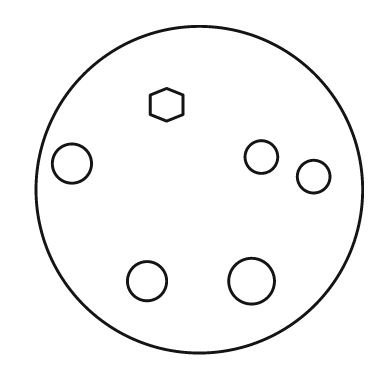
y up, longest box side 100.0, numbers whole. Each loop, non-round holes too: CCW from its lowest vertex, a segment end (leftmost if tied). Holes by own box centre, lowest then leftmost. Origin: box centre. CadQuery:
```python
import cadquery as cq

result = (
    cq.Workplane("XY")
    .moveTo(0.0, 0.0)
    .circle(50.0)
    .moveTo(-16.0, -28.0)
    .circle(6.0)
    .moveTo(16.0, -28.0)
    .circle(7.0)
    .moveTo(35.0, 4.0)
    .circle(5.0)
    .moveTo(-39.0, 8.0)
    .circle(6.0)
    .moveTo(19.0, 10.0)
    .circle(5.0)
    .moveTo(-10.0, 21.0)
    .lineTo(-5.0, 23.0)
    .lineTo(-5.0, 29.0)
    .lineTo(-10.0, 31.0)
    .lineTo(-15.0, 29.0)
    .lineTo(-15.0, 23.0)
    .close()
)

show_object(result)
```